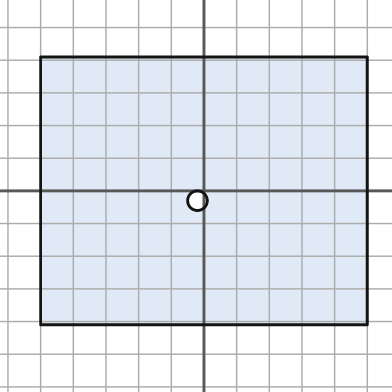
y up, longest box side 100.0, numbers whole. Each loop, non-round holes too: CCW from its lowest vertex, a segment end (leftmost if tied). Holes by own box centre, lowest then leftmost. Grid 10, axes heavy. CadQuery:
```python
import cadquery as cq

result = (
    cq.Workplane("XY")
    .moveTo(-50.0, -41.0)
    .lineTo(50.0, -41.0)
    .lineTo(50.0, 41.0)
    .lineTo(-50.0, 41.0)
    .close()
    .moveTo(-2.0, -3.0)
    .circle(3.0)
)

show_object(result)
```